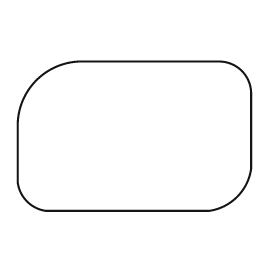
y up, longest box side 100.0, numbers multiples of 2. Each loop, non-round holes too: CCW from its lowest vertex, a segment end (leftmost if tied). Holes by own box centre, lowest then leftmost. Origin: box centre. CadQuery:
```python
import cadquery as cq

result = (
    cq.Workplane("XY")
    .moveTo(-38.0, -32.0)
    .lineTo(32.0, -32.0)
    .threePointArc((44.0, -26.0), (50.0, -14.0))
    .lineTo(50.0, 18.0)
    .threePointArc((46.0, 28.0), (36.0, 32.0))
    .lineTo(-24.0, 32.0)
    .threePointArc((-42.0, 24.0), (-50.0, 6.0))
    .lineTo(-50.0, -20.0)
    .threePointArc((-46.0, -28.0), (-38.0, -32.0))
    .close()
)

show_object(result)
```